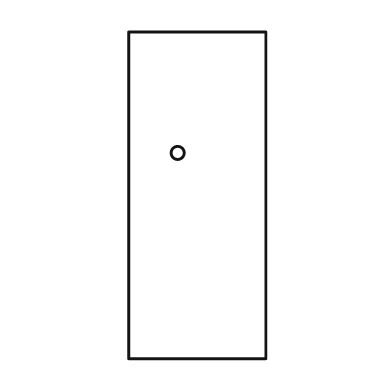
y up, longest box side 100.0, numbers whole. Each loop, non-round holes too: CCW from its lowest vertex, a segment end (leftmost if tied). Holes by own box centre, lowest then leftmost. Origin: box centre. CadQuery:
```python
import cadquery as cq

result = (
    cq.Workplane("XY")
    .moveTo(-21.0, -50.0)
    .lineTo(21.0, -50.0)
    .lineTo(21.0, 50.0)
    .lineTo(-21.0, 50.0)
    .close()
    .moveTo(-6.0, 13.0)
    .circle(2.0)
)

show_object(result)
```